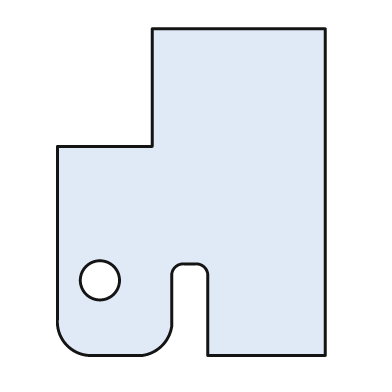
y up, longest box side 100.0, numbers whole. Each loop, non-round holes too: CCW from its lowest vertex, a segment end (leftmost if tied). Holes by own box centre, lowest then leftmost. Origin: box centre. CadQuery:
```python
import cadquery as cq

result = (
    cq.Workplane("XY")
    .moveTo(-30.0, -50.0)
    .lineTo(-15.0, -50.0)
    .threePointArc((-9.0, -47.0), (-6.0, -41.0))
    .lineTo(-6.0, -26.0)
    .threePointArc((-5.0, -23.0), (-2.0, -22.0))
    .lineTo(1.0, -22.0)
    .threePointArc((4.0, -23.0), (5.0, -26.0))
    .lineTo(5.0, -50.0)
    .lineTo(41.0, -50.0)
    .lineTo(41.0, 50.0)
    .lineTo(-12.0, 50.0)
    .lineTo(-12.0, 14.0)
    .lineTo(-41.0, 14.0)
    .lineTo(-41.0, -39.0)
    .threePointArc((-38.0, -47.0), (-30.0, -50.0))
    .close()
    .moveTo(-28.0, -27.0)
    .circle(6.0)
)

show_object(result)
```